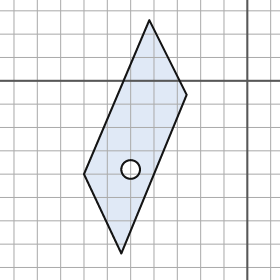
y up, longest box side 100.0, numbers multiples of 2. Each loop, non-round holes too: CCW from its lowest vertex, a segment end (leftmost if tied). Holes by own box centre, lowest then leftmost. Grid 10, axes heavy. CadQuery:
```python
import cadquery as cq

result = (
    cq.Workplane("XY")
    .moveTo(-54.0, -74.0)
    .lineTo(-26.0, -6.0)
    .lineTo(-42.0, 26.0)
    .lineTo(-70.0, -40.0)
    .close()
    .moveTo(-50.0, -38.0)
    .circle(4.0)
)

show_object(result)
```